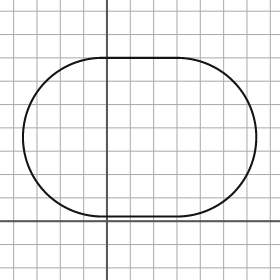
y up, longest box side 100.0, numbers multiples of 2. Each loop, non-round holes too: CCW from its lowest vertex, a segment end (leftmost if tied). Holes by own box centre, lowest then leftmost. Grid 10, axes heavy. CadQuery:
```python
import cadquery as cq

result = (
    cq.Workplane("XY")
    .moveTo(-2.0, 2.0)
    .lineTo(30.0, 2.0)
    .threePointArc((64.0, 36.0), (30.0, 70.0))
    .lineTo(-2.0, 70.0)
    .threePointArc((-36.0, 36.0), (-2.0, 2.0))
    .close()
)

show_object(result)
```